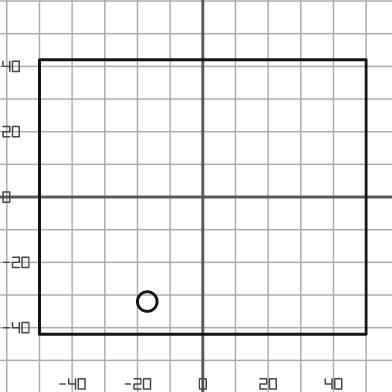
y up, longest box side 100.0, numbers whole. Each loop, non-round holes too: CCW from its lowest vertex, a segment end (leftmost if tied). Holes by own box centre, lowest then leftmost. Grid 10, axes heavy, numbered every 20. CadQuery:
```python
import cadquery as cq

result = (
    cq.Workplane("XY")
    .moveTo(-50.0, -42.0)
    .lineTo(50.0, -42.0)
    .lineTo(50.0, 42.0)
    .lineTo(-50.0, 42.0)
    .close()
    .moveTo(-17.0, -32.0)
    .circle(3.0)
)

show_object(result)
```